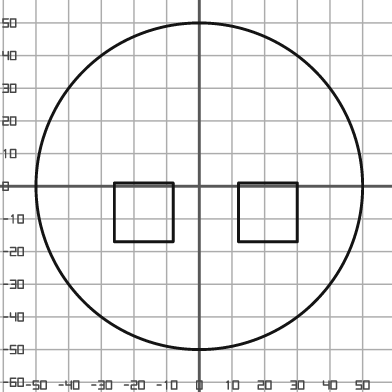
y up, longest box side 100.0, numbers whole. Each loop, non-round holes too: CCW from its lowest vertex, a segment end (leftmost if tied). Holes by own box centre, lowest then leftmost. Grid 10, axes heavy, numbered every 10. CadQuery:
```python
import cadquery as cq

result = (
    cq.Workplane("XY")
    .moveTo(0.0, 0.0)
    .circle(50.0)
    .moveTo(-26.0, -17.0)
    .lineTo(-8.0, -17.0)
    .lineTo(-8.0, 1.0)
    .lineTo(-26.0, 1.0)
    .close()
    .moveTo(12.0, -17.0)
    .lineTo(30.0, -17.0)
    .lineTo(30.0, 1.0)
    .lineTo(12.0, 1.0)
    .close()
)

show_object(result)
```